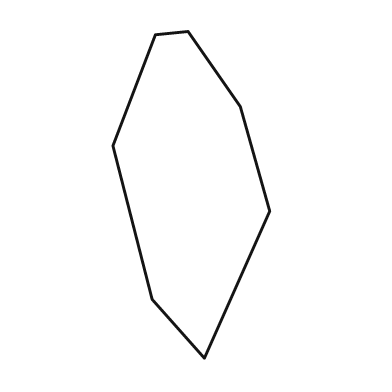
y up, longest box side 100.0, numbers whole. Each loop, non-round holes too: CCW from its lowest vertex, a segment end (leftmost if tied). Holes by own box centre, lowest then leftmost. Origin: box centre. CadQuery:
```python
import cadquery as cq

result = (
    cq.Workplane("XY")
    .moveTo(4.0, -50.0)
    .lineTo(24.0, -5.0)
    .lineTo(15.0, 27.0)
    .lineTo(-1.0, 50.0)
    .lineTo(-11.0, 49.0)
    .lineTo(-24.0, 15.0)
    .lineTo(-12.0, -32.0)
    .close()
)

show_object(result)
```